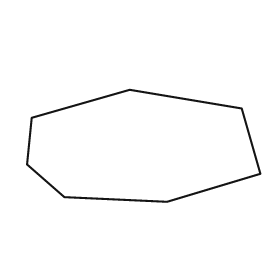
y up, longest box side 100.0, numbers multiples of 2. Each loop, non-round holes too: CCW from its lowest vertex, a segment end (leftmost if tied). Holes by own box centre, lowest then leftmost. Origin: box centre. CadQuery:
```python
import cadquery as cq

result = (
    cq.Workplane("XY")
    .moveTo(10.0, -24.0)
    .lineTo(50.0, -12.0)
    .lineTo(42.0, 16.0)
    .lineTo(-6.0, 24.0)
    .lineTo(-48.0, 12.0)
    .lineTo(-50.0, -8.0)
    .lineTo(-34.0, -22.0)
    .close()
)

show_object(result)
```